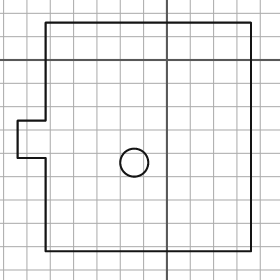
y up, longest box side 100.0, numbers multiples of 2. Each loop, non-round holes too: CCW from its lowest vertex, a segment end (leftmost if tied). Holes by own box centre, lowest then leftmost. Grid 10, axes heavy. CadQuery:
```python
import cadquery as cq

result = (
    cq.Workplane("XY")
    .moveTo(-52.0, -82.0)
    .lineTo(36.0, -82.0)
    .lineTo(36.0, 16.0)
    .lineTo(-52.0, 16.0)
    .lineTo(-52.0, -26.0)
    .lineTo(-64.0, -26.0)
    .lineTo(-64.0, -42.0)
    .lineTo(-52.0, -42.0)
    .close()
    .moveTo(-14.0, -44.0)
    .circle(6.0)
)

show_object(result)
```